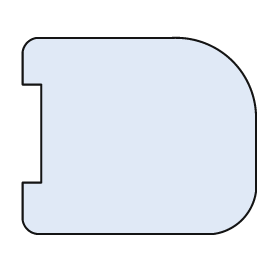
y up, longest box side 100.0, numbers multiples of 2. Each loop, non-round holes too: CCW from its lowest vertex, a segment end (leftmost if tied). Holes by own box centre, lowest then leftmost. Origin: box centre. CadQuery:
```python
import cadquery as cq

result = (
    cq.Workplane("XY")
    .moveTo(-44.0, -42.0)
    .lineTo(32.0, -42.0)
    .threePointArc((44.0, -36.0), (50.0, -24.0))
    .lineTo(50.0, 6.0)
    .threePointArc((40.0, 32.0), (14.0, 42.0))
    .lineTo(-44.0, 42.0)
    .threePointArc((-48.0, 40.0), (-50.0, 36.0))
    .lineTo(-50.0, 22.0)
    .lineTo(-42.0, 22.0)
    .lineTo(-42.0, -20.0)
    .lineTo(-50.0, -20.0)
    .lineTo(-50.0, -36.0)
    .threePointArc((-48.0, -40.0), (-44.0, -42.0))
    .close()
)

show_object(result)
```